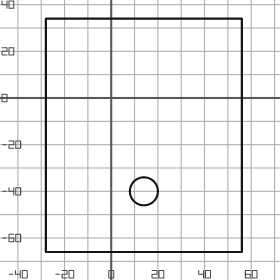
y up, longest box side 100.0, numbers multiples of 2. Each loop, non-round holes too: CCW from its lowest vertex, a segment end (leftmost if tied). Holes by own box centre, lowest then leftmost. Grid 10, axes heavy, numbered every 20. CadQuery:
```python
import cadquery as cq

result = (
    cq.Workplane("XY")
    .moveTo(-28.0, -66.0)
    .lineTo(56.0, -66.0)
    .lineTo(56.0, 34.0)
    .lineTo(-28.0, 34.0)
    .close()
    .moveTo(14.0, -40.0)
    .circle(6.0)
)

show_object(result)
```